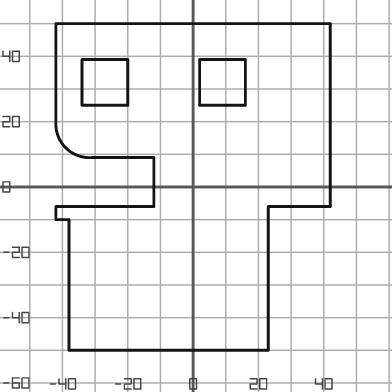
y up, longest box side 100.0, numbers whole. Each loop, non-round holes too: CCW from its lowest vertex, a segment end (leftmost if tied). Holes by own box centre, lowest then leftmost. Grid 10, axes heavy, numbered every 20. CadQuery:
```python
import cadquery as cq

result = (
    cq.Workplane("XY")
    .moveTo(-38.0, -50.0)
    .lineTo(23.0, -50.0)
    .lineTo(23.0, -6.0)
    .lineTo(42.0, -6.0)
    .lineTo(42.0, 50.0)
    .lineTo(-42.0, 50.0)
    .lineTo(-42.0, 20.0)
    .threePointArc((-39.0, 12.0), (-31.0, 9.0))
    .lineTo(-12.0, 9.0)
    .lineTo(-12.0, -6.0)
    .lineTo(-42.0, -6.0)
    .lineTo(-42.0, -10.0)
    .lineTo(-38.0, -10.0)
    .close()
    .moveTo(-34.0, 25.0)
    .lineTo(-20.0, 25.0)
    .lineTo(-20.0, 39.0)
    .lineTo(-34.0, 39.0)
    .close()
    .moveTo(2.0, 25.0)
    .lineTo(16.0, 25.0)
    .lineTo(16.0, 39.0)
    .lineTo(2.0, 39.0)
    .close()
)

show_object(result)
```